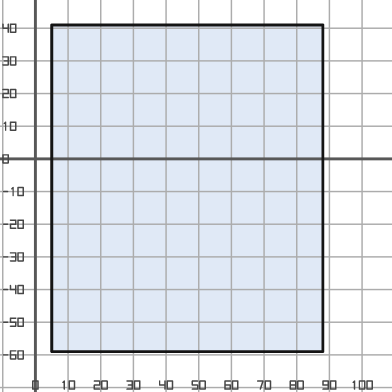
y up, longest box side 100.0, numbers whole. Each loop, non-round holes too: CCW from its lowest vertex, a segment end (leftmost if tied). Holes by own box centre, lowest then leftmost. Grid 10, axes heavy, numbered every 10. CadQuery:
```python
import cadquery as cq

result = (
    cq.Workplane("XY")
    .moveTo(5.0, -59.0)
    .lineTo(88.0, -59.0)
    .lineTo(88.0, 41.0)
    .lineTo(5.0, 41.0)
    .close()
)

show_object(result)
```